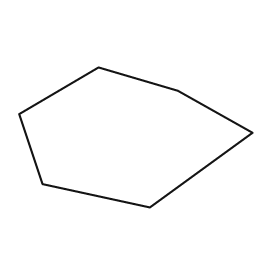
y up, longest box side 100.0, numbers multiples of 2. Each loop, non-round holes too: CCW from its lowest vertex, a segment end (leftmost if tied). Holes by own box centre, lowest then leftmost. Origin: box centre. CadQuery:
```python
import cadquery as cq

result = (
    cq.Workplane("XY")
    .moveTo(6.0, -30.0)
    .lineTo(50.0, 2.0)
    .lineTo(18.0, 20.0)
    .lineTo(-16.0, 30.0)
    .lineTo(-50.0, 10.0)
    .lineTo(-40.0, -20.0)
    .close()
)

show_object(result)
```